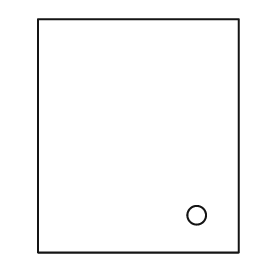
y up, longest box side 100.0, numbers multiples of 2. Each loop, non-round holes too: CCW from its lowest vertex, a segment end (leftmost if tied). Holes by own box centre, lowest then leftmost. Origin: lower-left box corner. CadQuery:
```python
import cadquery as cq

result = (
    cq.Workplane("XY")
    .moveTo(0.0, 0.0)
    .lineTo(86.0, 0.0)
    .lineTo(86.0, 100.0)
    .lineTo(0.0, 100.0)
    .close()
    .moveTo(68.0, 16.0)
    .circle(4.0)
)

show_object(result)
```